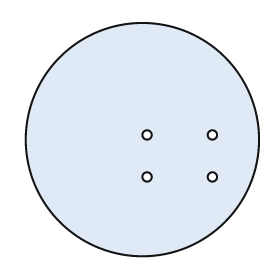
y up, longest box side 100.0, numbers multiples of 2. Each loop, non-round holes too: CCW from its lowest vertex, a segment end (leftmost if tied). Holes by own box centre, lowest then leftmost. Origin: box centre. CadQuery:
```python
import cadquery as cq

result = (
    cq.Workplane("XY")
    .moveTo(0.0, 0.0)
    .circle(50.0)
    .moveTo(2.0, -16.0)
    .circle(2.0)
    .moveTo(30.0, -16.0)
    .circle(2.0)
    .moveTo(2.0, 2.0)
    .circle(2.0)
    .moveTo(30.0, 2.0)
    .circle(2.0)
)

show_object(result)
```